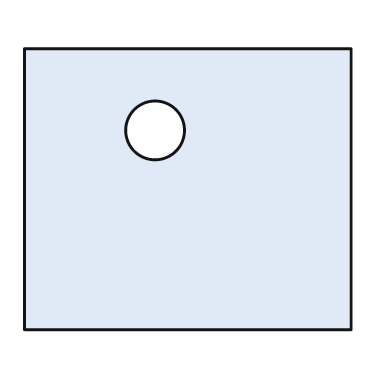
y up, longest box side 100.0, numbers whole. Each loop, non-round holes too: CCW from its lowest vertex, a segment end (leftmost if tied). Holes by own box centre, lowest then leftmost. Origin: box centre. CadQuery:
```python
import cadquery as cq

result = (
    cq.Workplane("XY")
    .moveTo(-50.0, -43.0)
    .lineTo(50.0, -43.0)
    .lineTo(50.0, 43.0)
    .lineTo(-50.0, 43.0)
    .close()
    .moveTo(-10.0, 18.0)
    .circle(9.0)
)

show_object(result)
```